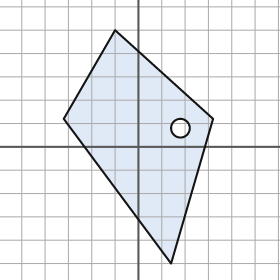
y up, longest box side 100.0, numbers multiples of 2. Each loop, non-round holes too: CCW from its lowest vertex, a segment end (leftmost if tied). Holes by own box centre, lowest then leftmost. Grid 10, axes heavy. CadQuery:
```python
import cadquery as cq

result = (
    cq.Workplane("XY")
    .moveTo(14.0, -50.0)
    .lineTo(32.0, 12.0)
    .lineTo(-10.0, 50.0)
    .lineTo(-32.0, 12.0)
    .close()
    .moveTo(18.0, 8.0)
    .circle(4.0)
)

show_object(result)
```